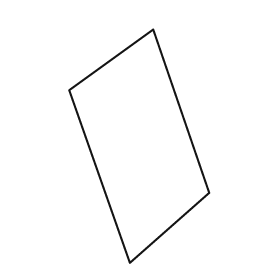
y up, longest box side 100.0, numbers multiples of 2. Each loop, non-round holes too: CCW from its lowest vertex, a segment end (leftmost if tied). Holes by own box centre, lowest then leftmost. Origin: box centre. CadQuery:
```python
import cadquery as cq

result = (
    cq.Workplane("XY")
    .moveTo(-4.0, -50.0)
    .lineTo(30.0, -20.0)
    .lineTo(6.0, 50.0)
    .lineTo(-30.0, 24.0)
    .close()
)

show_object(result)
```